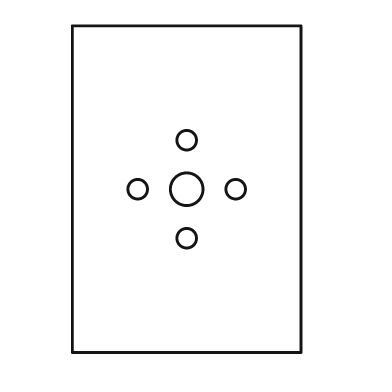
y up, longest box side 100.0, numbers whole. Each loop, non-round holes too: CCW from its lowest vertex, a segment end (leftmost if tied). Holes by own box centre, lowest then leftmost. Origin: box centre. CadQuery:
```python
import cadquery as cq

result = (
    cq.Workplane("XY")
    .moveTo(-35.0, -50.0)
    .lineTo(35.0, -50.0)
    .lineTo(35.0, 50.0)
    .lineTo(-35.0, 50.0)
    .close()
    .moveTo(0.0, -15.0)
    .circle(3.0)
    .moveTo(-15.0, 0.0)
    .circle(3.0)
    .moveTo(0.0, 0.0)
    .circle(5.0)
    .moveTo(15.0, 0.0)
    .circle(3.0)
    .moveTo(0.0, 15.0)
    .circle(3.0)
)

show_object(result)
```